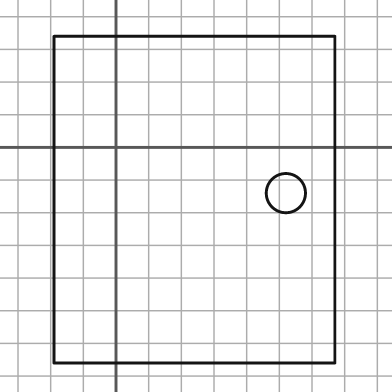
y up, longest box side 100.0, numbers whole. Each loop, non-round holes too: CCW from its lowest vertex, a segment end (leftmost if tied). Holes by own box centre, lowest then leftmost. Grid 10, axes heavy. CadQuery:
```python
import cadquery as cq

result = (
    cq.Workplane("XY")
    .moveTo(-19.0, -66.0)
    .lineTo(67.0, -66.0)
    .lineTo(67.0, 34.0)
    .lineTo(-19.0, 34.0)
    .close()
    .moveTo(52.0, -14.0)
    .circle(6.0)
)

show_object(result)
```